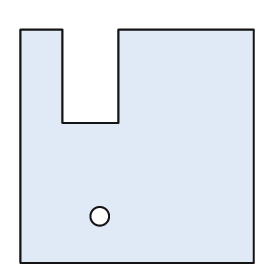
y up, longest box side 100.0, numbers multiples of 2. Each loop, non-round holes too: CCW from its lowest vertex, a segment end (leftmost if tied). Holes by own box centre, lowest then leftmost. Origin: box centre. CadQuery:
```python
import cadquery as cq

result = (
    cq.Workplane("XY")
    .moveTo(-50.0, -50.0)
    .lineTo(50.0, -50.0)
    .lineTo(50.0, 50.0)
    .lineTo(-8.0, 50.0)
    .lineTo(-8.0, 10.0)
    .lineTo(-32.0, 10.0)
    .lineTo(-32.0, 50.0)
    .lineTo(-50.0, 50.0)
    .close()
    .moveTo(-16.0, -30.0)
    .circle(4.0)
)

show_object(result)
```